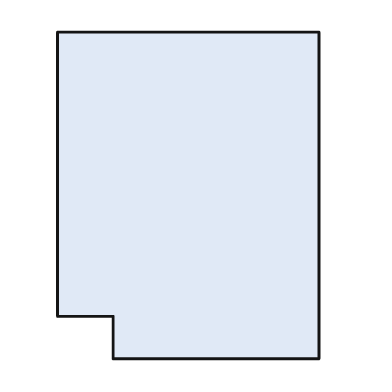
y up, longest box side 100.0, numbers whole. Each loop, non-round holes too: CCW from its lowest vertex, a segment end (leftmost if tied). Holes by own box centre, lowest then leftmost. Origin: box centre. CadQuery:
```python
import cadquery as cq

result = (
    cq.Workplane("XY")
    .moveTo(-23.0, -50.0)
    .lineTo(40.0, -50.0)
    .lineTo(40.0, 50.0)
    .lineTo(-40.0, 50.0)
    .lineTo(-40.0, -37.0)
    .lineTo(-23.0, -37.0)
    .close()
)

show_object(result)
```